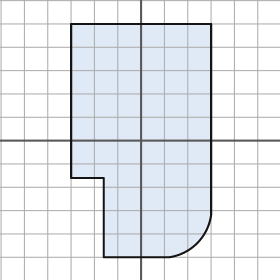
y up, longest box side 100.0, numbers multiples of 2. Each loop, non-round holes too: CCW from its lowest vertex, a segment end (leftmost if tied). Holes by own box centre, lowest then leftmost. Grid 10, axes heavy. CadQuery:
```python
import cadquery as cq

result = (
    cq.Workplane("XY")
    .moveTo(-16.0, -50.0)
    .lineTo(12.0, -50.0)
    .threePointArc((24.0, -44.0), (30.0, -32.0))
    .lineTo(30.0, 50.0)
    .lineTo(-30.0, 50.0)
    .lineTo(-30.0, -16.0)
    .lineTo(-16.0, -16.0)
    .close()
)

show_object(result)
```